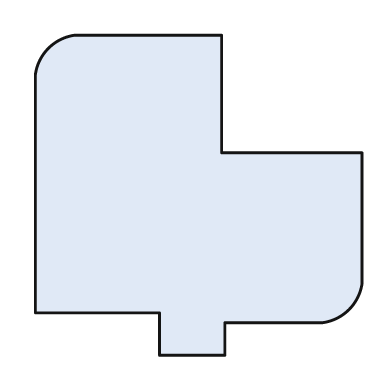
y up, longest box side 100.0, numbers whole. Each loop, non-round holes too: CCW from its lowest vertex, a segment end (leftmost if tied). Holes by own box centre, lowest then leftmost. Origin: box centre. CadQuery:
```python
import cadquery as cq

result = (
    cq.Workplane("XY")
    .moveTo(-12.0, -49.0)
    .lineTo(8.0, -49.0)
    .lineTo(8.0, -39.0)
    .lineTo(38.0, -39.0)
    .threePointArc((46.0, -35.0), (50.0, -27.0))
    .lineTo(50.0, 13.0)
    .lineTo(7.0, 13.0)
    .lineTo(7.0, 49.0)
    .lineTo(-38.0, 49.0)
    .threePointArc((-46.0, 45.0), (-50.0, 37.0))
    .lineTo(-50.0, -36.0)
    .lineTo(-12.0, -36.0)
    .close()
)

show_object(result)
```